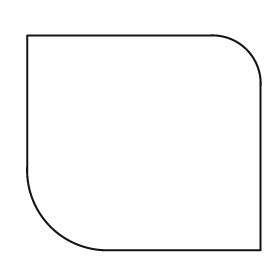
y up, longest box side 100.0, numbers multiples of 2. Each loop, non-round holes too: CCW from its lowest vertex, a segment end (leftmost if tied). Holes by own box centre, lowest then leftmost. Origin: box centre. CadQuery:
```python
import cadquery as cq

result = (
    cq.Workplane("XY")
    .moveTo(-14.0, -46.0)
    .lineTo(50.0, -46.0)
    .lineTo(50.0, 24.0)
    .threePointArc((44.0, 40.0), (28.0, 46.0))
    .lineTo(-50.0, 46.0)
    .lineTo(-50.0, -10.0)
    .threePointArc((-40.0, -36.0), (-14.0, -46.0))
    .close()
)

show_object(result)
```